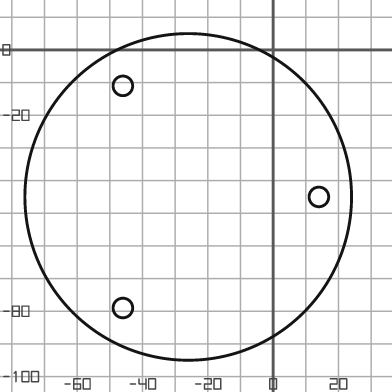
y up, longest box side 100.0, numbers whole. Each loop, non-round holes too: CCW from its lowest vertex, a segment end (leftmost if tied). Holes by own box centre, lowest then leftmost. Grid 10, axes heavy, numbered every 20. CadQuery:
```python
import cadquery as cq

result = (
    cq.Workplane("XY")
    .moveTo(-26.0, -45.0)
    .circle(50.0)
    .moveTo(-46.0, -79.0)
    .circle(3.0)
    .moveTo(14.0, -45.0)
    .circle(3.0)
    .moveTo(-46.0, -11.0)
    .circle(3.0)
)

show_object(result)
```